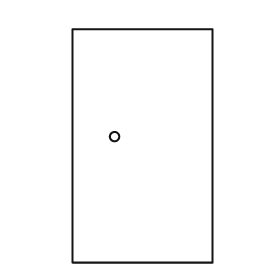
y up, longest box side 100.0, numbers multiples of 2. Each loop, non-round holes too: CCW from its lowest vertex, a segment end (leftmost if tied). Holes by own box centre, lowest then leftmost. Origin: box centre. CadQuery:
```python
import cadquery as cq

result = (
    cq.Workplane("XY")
    .moveTo(-30.0, -50.0)
    .lineTo(30.0, -50.0)
    .lineTo(30.0, 50.0)
    .lineTo(-30.0, 50.0)
    .close()
    .moveTo(-12.0, 4.0)
    .circle(2.0)
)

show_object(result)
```